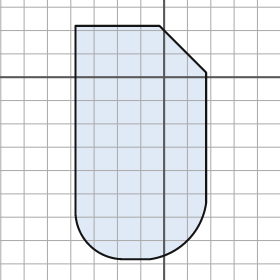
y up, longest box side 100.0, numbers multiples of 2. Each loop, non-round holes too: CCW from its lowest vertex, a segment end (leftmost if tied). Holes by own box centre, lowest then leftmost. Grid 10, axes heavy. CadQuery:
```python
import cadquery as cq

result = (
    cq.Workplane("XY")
    .moveTo(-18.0, -78.0)
    .lineTo(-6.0, -78.0)
    .threePointArc((10.0, -70.0), (18.0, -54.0))
    .lineTo(18.0, 2.0)
    .lineTo(-2.0, 22.0)
    .lineTo(-38.0, 22.0)
    .lineTo(-38.0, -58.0)
    .threePointArc((-32.0, -72.0), (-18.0, -78.0))
    .close()
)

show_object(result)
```